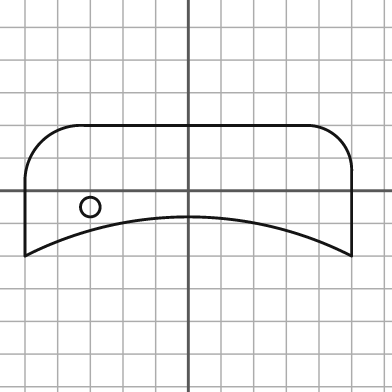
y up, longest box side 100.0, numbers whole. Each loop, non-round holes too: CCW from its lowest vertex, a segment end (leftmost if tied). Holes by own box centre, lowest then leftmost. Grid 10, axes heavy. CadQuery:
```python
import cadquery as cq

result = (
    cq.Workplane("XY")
    .moveTo(-50.0, -20.0)
    .threePointArc((0.0, -8.0), (50.0, -20.0))
    .lineTo(50.0, 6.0)
    .threePointArc((46.0, 16.0), (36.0, 20.0))
    .lineTo(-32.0, 20.0)
    .threePointArc((-45.0, 15.0), (-50.0, 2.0))
    .close()
    .moveTo(-30.0, -5.0)
    .circle(3.0)
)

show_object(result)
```